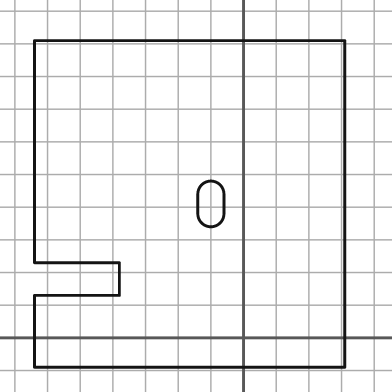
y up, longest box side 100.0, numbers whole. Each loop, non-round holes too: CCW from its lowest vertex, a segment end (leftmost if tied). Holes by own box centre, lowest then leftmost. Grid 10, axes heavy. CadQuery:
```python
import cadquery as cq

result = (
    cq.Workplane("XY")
    .moveTo(-64.0, -9.0)
    .lineTo(31.0, -9.0)
    .lineTo(31.0, 91.0)
    .lineTo(-64.0, 91.0)
    .lineTo(-64.0, 23.0)
    .lineTo(-38.0, 23.0)
    .lineTo(-38.0, 13.0)
    .lineTo(-64.0, 13.0)
    .close()
    .moveTo(-14.0, 38.0)
    .threePointArc((-10.0, 34.0), (-6.0, 38.0))
    .lineTo(-6.0, 44.0)
    .threePointArc((-10.0, 48.0), (-14.0, 44.0))
    .close()
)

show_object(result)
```